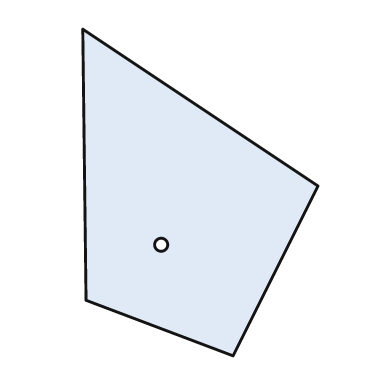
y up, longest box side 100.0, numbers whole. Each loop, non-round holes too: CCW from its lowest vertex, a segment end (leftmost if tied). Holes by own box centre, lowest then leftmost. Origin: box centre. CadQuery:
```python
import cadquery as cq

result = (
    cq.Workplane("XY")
    .moveTo(10.0, -50.0)
    .lineTo(36.0, 2.0)
    .lineTo(-36.0, 50.0)
    .lineTo(-35.0, -33.0)
    .close()
    .moveTo(-12.0, -16.0)
    .circle(2.0)
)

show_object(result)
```